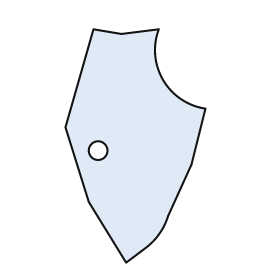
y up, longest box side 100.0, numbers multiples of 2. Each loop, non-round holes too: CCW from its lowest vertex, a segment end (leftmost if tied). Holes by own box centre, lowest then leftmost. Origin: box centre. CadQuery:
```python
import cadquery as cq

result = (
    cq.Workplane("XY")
    .moveTo(-4.0, -50.0)
    .lineTo(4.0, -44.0)
    .threePointArc((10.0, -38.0), (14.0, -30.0))
    .lineTo(24.0, -8.0)
    .lineTo(30.0, 16.0)
    .threePointArc((12.0, 28.0), (10.0, 50.0))
    .lineTo(-6.0, 48.0)
    .lineTo(-18.0, 50.0)
    .lineTo(-30.0, 8.0)
    .lineTo(-20.0, -24.0)
    .close()
    .moveTo(-16.0, -2.0)
    .circle(4.0)
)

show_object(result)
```